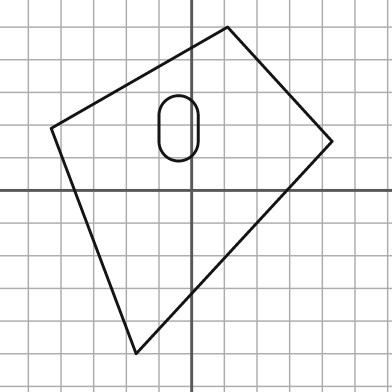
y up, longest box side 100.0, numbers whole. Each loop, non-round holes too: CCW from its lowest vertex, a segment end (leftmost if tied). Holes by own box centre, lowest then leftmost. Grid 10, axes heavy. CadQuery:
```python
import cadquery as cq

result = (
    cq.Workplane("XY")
    .moveTo(-17.0, -50.0)
    .lineTo(43.0, 15.0)
    .lineTo(11.0, 50.0)
    .lineTo(-43.0, 19.0)
    .close()
    .moveTo(-10.0, 15.0)
    .threePointArc((-4.0, 9.0), (2.0, 15.0))
    .lineTo(2.0, 23.0)
    .threePointArc((-4.0, 29.0), (-10.0, 23.0))
    .close()
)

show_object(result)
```